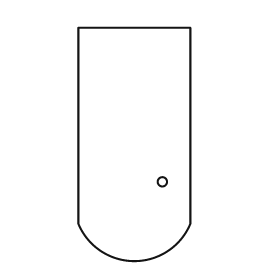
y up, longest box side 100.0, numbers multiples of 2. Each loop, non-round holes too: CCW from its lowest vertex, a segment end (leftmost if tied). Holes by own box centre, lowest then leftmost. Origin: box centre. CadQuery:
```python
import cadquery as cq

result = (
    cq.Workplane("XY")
    .moveTo(-24.0, -34.0)
    .threePointArc((0.0, -50.0), (24.0, -34.0))
    .lineTo(24.0, 50.0)
    .lineTo(-24.0, 50.0)
    .close()
    .moveTo(12.0, -16.0)
    .circle(2.0)
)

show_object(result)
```